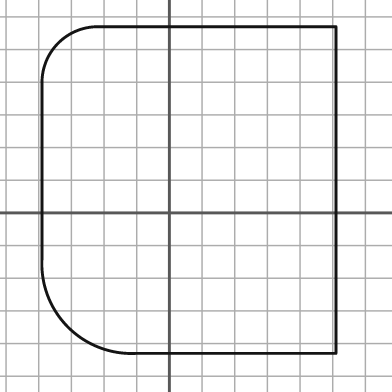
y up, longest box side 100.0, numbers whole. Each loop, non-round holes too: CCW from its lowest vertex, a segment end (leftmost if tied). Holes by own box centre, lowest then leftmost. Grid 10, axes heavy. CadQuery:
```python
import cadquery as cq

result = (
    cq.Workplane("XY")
    .moveTo(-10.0, -43.0)
    .lineTo(51.0, -43.0)
    .lineTo(51.0, 57.0)
    .lineTo(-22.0, 57.0)
    .threePointArc((-34.0, 52.0), (-39.0, 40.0))
    .lineTo(-39.0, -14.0)
    .threePointArc((-31.0, -35.0), (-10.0, -43.0))
    .close()
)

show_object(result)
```